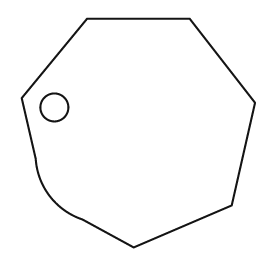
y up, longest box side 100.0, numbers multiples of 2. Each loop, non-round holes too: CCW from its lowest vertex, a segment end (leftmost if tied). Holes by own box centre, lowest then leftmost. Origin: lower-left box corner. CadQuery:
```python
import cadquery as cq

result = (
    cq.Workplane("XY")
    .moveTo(48.0, 0.0)
    .lineTo(90.0, 18.0)
    .lineTo(100.0, 62.0)
    .lineTo(72.0, 98.0)
    .lineTo(28.0, 98.0)
    .lineTo(0.0, 64.0)
    .lineTo(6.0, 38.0)
    .threePointArc((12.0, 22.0), (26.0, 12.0))
    .close()
    .moveTo(14.0, 60.0)
    .circle(6.0)
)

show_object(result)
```